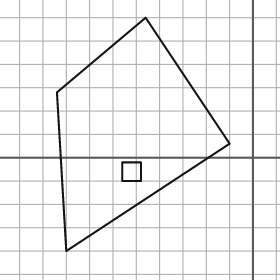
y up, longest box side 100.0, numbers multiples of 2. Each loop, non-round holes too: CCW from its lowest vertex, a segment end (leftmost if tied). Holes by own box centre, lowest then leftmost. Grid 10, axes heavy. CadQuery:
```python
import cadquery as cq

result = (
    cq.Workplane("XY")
    .moveTo(-80.0, -40.0)
    .lineTo(-10.0, 6.0)
    .lineTo(-46.0, 60.0)
    .lineTo(-84.0, 28.0)
    .close()
    .moveTo(-56.0, -10.0)
    .lineTo(-48.0, -10.0)
    .lineTo(-48.0, -2.0)
    .lineTo(-56.0, -2.0)
    .close()
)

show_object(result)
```